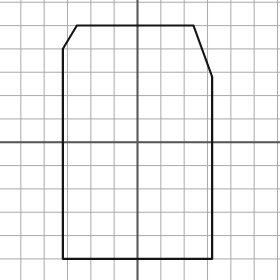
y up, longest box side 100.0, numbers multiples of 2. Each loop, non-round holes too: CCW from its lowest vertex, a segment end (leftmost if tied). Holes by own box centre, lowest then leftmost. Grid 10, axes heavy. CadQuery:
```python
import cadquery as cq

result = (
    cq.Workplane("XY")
    .moveTo(-32.0, -50.0)
    .lineTo(32.0, -50.0)
    .lineTo(32.0, 28.0)
    .lineTo(24.0, 50.0)
    .lineTo(-26.0, 50.0)
    .lineTo(-32.0, 40.0)
    .close()
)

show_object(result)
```